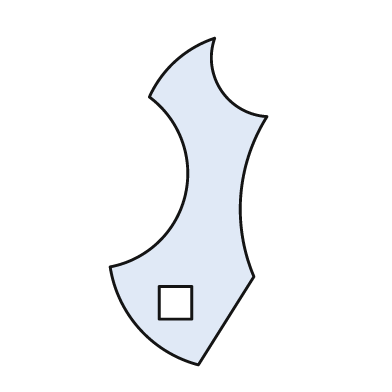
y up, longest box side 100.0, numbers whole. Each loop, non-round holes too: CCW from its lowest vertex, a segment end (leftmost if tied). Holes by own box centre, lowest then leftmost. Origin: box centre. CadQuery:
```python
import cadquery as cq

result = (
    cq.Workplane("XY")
    .moveTo(3.0, -50.0)
    .lineTo(20.0, -23.0)
    .threePointArc((16.0, 2.0), (24.0, 26.0))
    .threePointArc((10.0, 34.0), (8.0, 50.0))
    .threePointArc((-4.0, 43.0), (-12.0, 32.0))
    .threePointArc((-1.0, 2.0), (-24.0, -20.0))
    .threePointArc((-15.0, -39.0), (3.0, -50.0))
    .close()
    .moveTo(-9.0, -36.0)
    .lineTo(1.0, -36.0)
    .lineTo(1.0, -26.0)
    .lineTo(-9.0, -26.0)
    .close()
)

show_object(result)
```